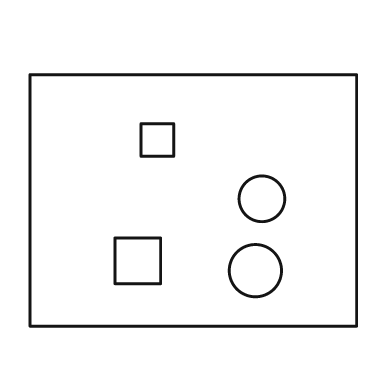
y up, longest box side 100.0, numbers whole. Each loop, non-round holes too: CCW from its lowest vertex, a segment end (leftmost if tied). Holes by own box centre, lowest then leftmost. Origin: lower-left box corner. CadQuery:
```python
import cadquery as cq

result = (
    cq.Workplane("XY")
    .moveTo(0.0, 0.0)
    .lineTo(100.0, 0.0)
    .lineTo(100.0, 77.0)
    .lineTo(0.0, 77.0)
    .close()
    .moveTo(69.0, 17.0)
    .circle(8.0)
    .moveTo(26.0, 13.0)
    .lineTo(40.0, 13.0)
    .lineTo(40.0, 27.0)
    .lineTo(26.0, 27.0)
    .close()
    .moveTo(71.0, 39.0)
    .circle(7.0)
    .moveTo(34.0, 52.0)
    .lineTo(44.0, 52.0)
    .lineTo(44.0, 62.0)
    .lineTo(34.0, 62.0)
    .close()
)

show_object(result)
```